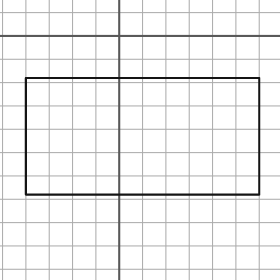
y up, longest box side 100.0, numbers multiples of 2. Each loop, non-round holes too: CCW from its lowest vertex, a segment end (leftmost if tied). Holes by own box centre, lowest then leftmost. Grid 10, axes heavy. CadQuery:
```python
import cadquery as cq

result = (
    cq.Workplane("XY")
    .moveTo(-40.0, -68.0)
    .lineTo(60.0, -68.0)
    .lineTo(60.0, -18.0)
    .lineTo(-40.0, -18.0)
    .close()
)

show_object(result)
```